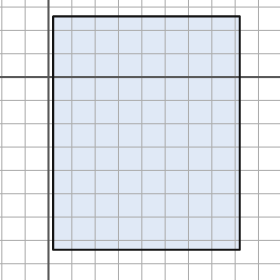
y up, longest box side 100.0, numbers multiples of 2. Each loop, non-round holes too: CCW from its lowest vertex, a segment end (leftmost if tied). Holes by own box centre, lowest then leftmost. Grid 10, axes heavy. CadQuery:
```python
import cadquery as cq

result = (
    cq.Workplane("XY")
    .moveTo(2.0, -74.0)
    .lineTo(82.0, -74.0)
    .lineTo(82.0, 26.0)
    .lineTo(2.0, 26.0)
    .close()
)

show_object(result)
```